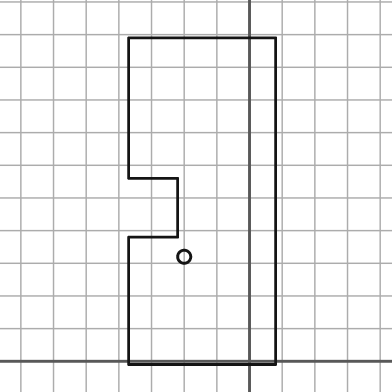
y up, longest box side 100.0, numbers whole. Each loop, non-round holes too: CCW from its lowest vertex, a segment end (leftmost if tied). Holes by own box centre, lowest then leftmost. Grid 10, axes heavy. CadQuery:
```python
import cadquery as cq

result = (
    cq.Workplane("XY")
    .moveTo(-37.0, -1.0)
    .lineTo(8.0, -1.0)
    .lineTo(8.0, 99.0)
    .lineTo(-37.0, 99.0)
    .lineTo(-37.0, 56.0)
    .lineTo(-22.0, 56.0)
    .lineTo(-22.0, 38.0)
    .lineTo(-37.0, 38.0)
    .close()
    .moveTo(-20.0, 32.0)
    .circle(2.0)
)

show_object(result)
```